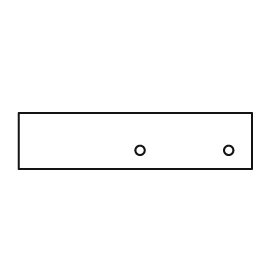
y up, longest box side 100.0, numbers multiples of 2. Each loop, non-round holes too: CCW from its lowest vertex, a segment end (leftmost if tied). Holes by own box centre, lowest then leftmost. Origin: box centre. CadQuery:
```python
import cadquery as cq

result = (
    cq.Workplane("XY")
    .moveTo(-50.0, -12.0)
    .lineTo(50.0, -12.0)
    .lineTo(50.0, 12.0)
    .lineTo(-50.0, 12.0)
    .close()
    .moveTo(2.0, -4.0)
    .circle(2.0)
    .moveTo(40.0, -4.0)
    .circle(2.0)
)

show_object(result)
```